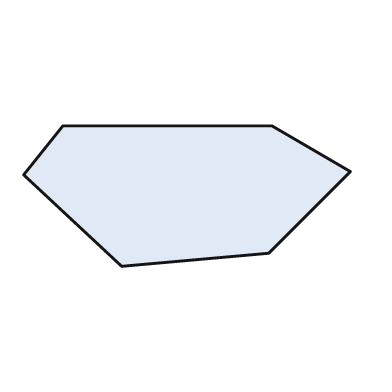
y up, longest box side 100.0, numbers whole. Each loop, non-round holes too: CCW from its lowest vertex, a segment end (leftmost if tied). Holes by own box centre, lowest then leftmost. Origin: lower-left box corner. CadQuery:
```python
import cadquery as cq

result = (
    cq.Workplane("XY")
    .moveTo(30.0, 0.0)
    .lineTo(75.0, 4.0)
    .lineTo(100.0, 29.0)
    .lineTo(76.0, 43.0)
    .lineTo(12.0, 43.0)
    .lineTo(0.0, 28.0)
    .close()
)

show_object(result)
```